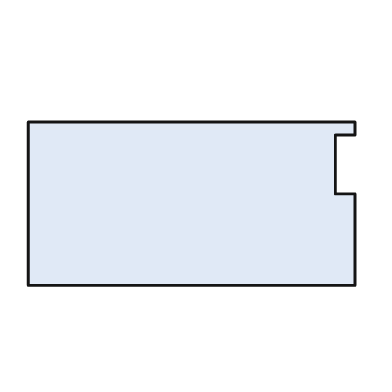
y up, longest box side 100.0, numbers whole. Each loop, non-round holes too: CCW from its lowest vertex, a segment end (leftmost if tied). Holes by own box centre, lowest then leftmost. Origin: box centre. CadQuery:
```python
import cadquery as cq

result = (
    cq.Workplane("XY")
    .moveTo(-50.0, -25.0)
    .lineTo(50.0, -25.0)
    .lineTo(50.0, 3.0)
    .lineTo(44.0, 3.0)
    .lineTo(44.0, 21.0)
    .lineTo(50.0, 21.0)
    .lineTo(50.0, 25.0)
    .lineTo(-50.0, 25.0)
    .close()
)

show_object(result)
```